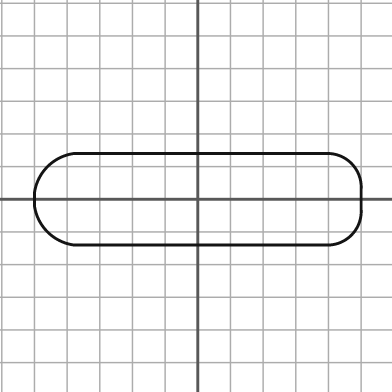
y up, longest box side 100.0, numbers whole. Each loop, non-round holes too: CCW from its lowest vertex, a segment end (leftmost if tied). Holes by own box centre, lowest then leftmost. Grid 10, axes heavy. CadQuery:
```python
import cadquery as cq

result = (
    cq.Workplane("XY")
    .moveTo(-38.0, -14.0)
    .lineTo(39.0, -14.0)
    .threePointArc((47.0, -11.0), (50.0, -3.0))
    .lineTo(50.0, 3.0)
    .threePointArc((47.0, 11.0), (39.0, 14.0))
    .lineTo(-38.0, 14.0)
    .threePointArc((-46.0, 10.0), (-50.0, 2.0))
    .lineTo(-50.0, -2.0)
    .threePointArc((-46.0, -10.0), (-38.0, -14.0))
    .close()
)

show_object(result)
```